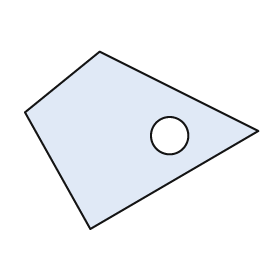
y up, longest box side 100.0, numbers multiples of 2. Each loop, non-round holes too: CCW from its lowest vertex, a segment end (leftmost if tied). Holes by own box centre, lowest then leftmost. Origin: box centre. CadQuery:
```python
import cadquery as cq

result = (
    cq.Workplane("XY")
    .moveTo(-22.0, -38.0)
    .lineTo(50.0, 4.0)
    .lineTo(-18.0, 38.0)
    .lineTo(-50.0, 12.0)
    .close()
    .moveTo(12.0, 2.0)
    .circle(8.0)
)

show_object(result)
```